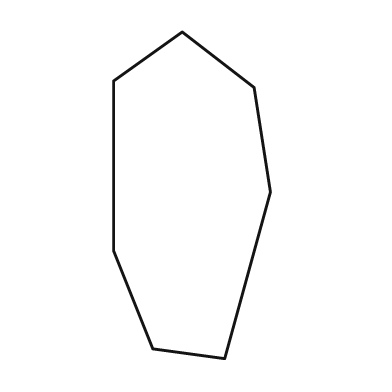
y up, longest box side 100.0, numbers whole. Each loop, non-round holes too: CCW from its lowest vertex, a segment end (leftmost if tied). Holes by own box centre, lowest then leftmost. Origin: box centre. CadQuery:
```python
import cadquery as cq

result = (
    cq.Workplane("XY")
    .moveTo(10.0, -50.0)
    .lineTo(24.0, 1.0)
    .lineTo(19.0, 33.0)
    .lineTo(-3.0, 50.0)
    .lineTo(-24.0, 35.0)
    .lineTo(-24.0, -17.0)
    .lineTo(-12.0, -47.0)
    .close()
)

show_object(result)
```